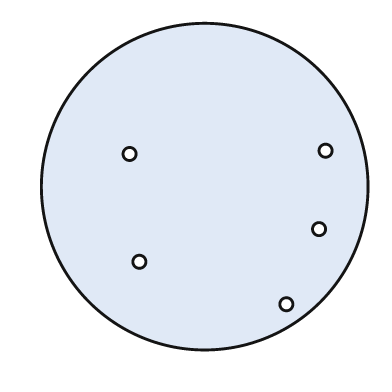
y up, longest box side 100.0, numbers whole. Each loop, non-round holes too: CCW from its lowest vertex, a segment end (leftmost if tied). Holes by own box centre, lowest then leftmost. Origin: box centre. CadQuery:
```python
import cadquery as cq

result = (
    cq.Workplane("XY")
    .moveTo(0.0, 0.0)
    .circle(50.0)
    .moveTo(25.0, -36.0)
    .circle(2.0)
    .moveTo(-20.0, -23.0)
    .circle(2.0)
    .moveTo(35.0, -13.0)
    .circle(2.0)
    .moveTo(-23.0, 10.0)
    .circle(2.0)
    .moveTo(37.0, 11.0)
    .circle(2.0)
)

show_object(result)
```